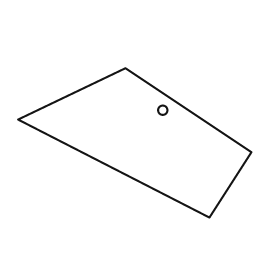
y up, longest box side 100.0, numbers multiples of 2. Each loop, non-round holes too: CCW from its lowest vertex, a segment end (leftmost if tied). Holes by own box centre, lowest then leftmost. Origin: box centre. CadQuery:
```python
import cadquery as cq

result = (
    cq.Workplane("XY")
    .moveTo(32.0, -32.0)
    .lineTo(50.0, -4.0)
    .lineTo(-4.0, 32.0)
    .lineTo(-50.0, 10.0)
    .close()
    .moveTo(12.0, 14.0)
    .circle(2.0)
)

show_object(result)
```